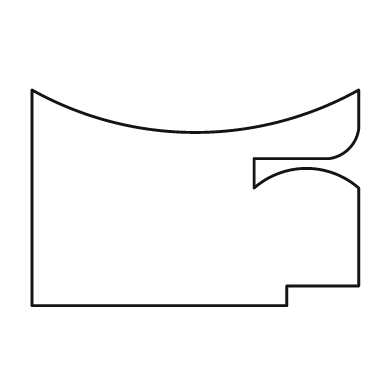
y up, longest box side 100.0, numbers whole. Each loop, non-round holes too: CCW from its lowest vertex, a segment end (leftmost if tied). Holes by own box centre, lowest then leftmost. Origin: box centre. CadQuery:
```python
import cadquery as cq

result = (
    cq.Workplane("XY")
    .moveTo(-50.0, -33.0)
    .lineTo(28.0, -33.0)
    .lineTo(28.0, -27.0)
    .lineTo(50.0, -27.0)
    .lineTo(50.0, 3.0)
    .threePointArc((34.0, 9.0), (18.0, 3.0))
    .lineTo(18.0, 12.0)
    .lineTo(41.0, 12.0)
    .threePointArc((47.0, 15.0), (50.0, 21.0))
    .lineTo(50.0, 33.0)
    .threePointArc((0.0, 20.0), (-50.0, 33.0))
    .close()
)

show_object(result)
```